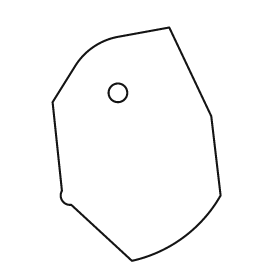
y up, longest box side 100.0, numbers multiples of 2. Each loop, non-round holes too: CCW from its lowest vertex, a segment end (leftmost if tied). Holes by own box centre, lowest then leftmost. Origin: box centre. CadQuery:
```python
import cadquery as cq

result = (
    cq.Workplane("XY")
    .moveTo(-2.0, -50.0)
    .threePointArc((20.0, -40.0), (36.0, -22.0))
    .lineTo(32.0, 12.0)
    .lineTo(14.0, 50.0)
    .lineTo(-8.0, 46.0)
    .threePointArc((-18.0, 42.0), (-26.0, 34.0))
    .lineTo(-36.0, 18.0)
    .lineTo(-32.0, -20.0)
    .threePointArc((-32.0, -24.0), (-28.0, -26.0))
    .close()
    .moveTo(-8.0, 22.0)
    .circle(4.0)
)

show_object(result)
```